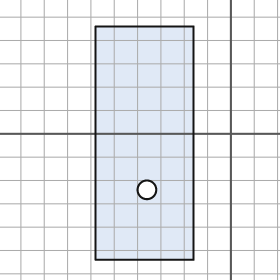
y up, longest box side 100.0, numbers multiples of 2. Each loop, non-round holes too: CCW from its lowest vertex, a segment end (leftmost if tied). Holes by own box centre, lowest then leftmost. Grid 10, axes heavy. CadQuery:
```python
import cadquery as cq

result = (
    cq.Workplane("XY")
    .moveTo(-58.0, -54.0)
    .lineTo(-16.0, -54.0)
    .lineTo(-16.0, 46.0)
    .lineTo(-58.0, 46.0)
    .close()
    .moveTo(-36.0, -24.0)
    .circle(4.0)
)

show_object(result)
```